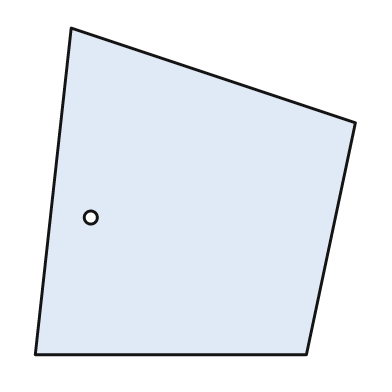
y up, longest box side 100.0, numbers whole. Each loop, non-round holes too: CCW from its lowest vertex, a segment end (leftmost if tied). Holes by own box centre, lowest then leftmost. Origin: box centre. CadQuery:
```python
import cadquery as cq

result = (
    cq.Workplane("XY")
    .moveTo(-49.0, -50.0)
    .lineTo(34.0, -50.0)
    .lineTo(49.0, 21.0)
    .lineTo(-38.0, 50.0)
    .close()
    .moveTo(-32.0, -8.0)
    .circle(2.0)
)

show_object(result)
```